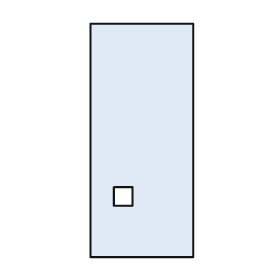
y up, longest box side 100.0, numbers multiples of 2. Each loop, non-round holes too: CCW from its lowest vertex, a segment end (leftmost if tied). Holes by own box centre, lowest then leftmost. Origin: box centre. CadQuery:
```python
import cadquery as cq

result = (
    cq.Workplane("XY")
    .moveTo(-22.0, -50.0)
    .lineTo(22.0, -50.0)
    .lineTo(22.0, 50.0)
    .lineTo(-22.0, 50.0)
    .close()
    .moveTo(-12.0, -28.0)
    .lineTo(-4.0, -28.0)
    .lineTo(-4.0, -20.0)
    .lineTo(-12.0, -20.0)
    .close()
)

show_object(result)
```